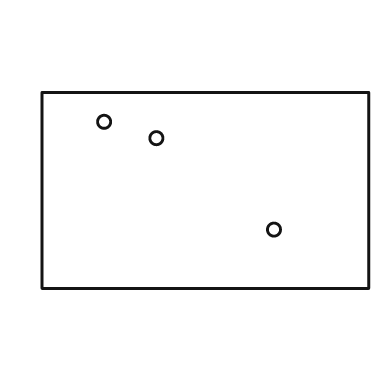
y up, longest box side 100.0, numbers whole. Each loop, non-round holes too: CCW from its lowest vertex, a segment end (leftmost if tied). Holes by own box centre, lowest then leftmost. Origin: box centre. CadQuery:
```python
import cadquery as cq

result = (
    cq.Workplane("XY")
    .moveTo(-50.0, -30.0)
    .lineTo(50.0, -30.0)
    .lineTo(50.0, 30.0)
    .lineTo(-50.0, 30.0)
    .close()
    .moveTo(21.0, -12.0)
    .circle(2.0)
    .moveTo(-15.0, 16.0)
    .circle(2.0)
    .moveTo(-31.0, 21.0)
    .circle(2.0)
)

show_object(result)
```